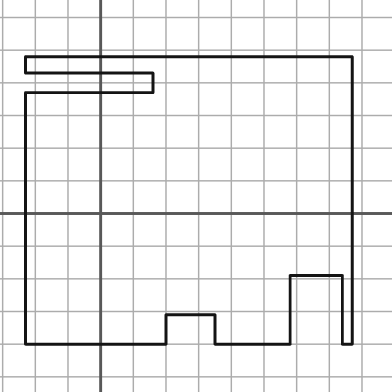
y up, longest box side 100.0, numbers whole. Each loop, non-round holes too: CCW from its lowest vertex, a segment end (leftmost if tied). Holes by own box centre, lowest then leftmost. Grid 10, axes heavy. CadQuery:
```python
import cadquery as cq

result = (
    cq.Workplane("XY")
    .moveTo(-23.0, -40.0)
    .lineTo(20.0, -40.0)
    .lineTo(20.0, -31.0)
    .lineTo(35.0, -31.0)
    .lineTo(35.0, -40.0)
    .lineTo(58.0, -40.0)
    .lineTo(58.0, -19.0)
    .lineTo(74.0, -19.0)
    .lineTo(74.0, -40.0)
    .lineTo(77.0, -40.0)
    .lineTo(77.0, 48.0)
    .lineTo(-23.0, 48.0)
    .lineTo(-23.0, 43.0)
    .lineTo(16.0, 43.0)
    .lineTo(16.0, 37.0)
    .lineTo(-23.0, 37.0)
    .close()
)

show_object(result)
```